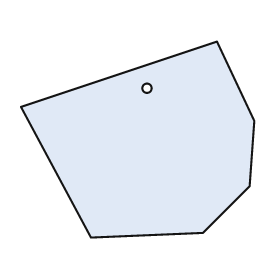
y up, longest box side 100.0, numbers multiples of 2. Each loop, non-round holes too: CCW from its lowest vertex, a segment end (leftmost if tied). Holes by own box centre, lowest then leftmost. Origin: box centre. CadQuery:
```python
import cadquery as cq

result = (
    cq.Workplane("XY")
    .moveTo(-20.0, -42.0)
    .lineTo(28.0, -40.0)
    .lineTo(48.0, -20.0)
    .lineTo(50.0, 8.0)
    .lineTo(34.0, 42.0)
    .lineTo(-50.0, 14.0)
    .close()
    .moveTo(4.0, 22.0)
    .circle(2.0)
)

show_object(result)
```